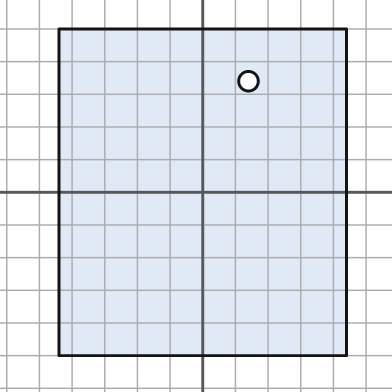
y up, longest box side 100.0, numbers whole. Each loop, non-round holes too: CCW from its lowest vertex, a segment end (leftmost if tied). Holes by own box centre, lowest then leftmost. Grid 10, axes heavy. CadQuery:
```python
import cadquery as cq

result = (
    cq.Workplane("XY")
    .moveTo(-44.0, -50.0)
    .lineTo(44.0, -50.0)
    .lineTo(44.0, 50.0)
    .lineTo(-44.0, 50.0)
    .close()
    .moveTo(14.0, 34.0)
    .circle(3.0)
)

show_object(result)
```